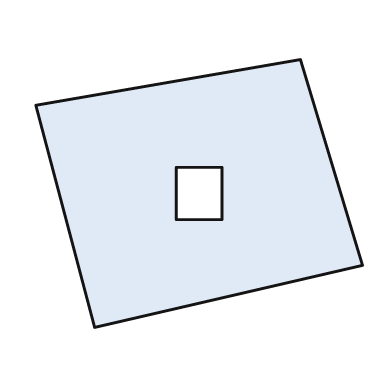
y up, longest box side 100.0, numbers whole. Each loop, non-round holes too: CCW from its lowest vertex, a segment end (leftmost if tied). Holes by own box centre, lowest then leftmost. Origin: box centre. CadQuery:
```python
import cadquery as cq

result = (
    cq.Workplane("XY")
    .moveTo(-32.0, -41.0)
    .lineTo(50.0, -22.0)
    .lineTo(31.0, 41.0)
    .lineTo(-50.0, 27.0)
    .close()
    .moveTo(-7.0, -8.0)
    .lineTo(7.0, -8.0)
    .lineTo(7.0, 8.0)
    .lineTo(-7.0, 8.0)
    .close()
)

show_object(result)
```